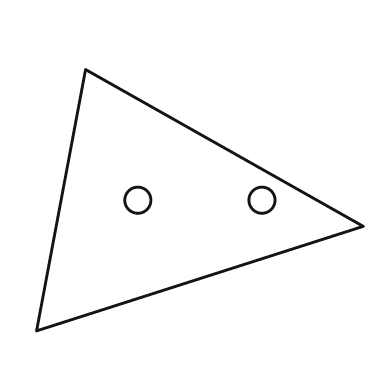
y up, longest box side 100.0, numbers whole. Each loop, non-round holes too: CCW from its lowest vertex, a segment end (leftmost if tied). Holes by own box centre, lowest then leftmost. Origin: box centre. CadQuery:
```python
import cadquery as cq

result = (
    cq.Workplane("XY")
    .moveTo(-50.0, -40.0)
    .lineTo(50.0, -8.0)
    .lineTo(-35.0, 40.0)
    .close()
    .moveTo(-19.0, 0.0)
    .circle(4.0)
    .moveTo(19.0, 0.0)
    .circle(4.0)
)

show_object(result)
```